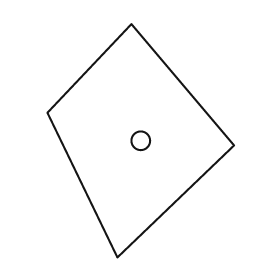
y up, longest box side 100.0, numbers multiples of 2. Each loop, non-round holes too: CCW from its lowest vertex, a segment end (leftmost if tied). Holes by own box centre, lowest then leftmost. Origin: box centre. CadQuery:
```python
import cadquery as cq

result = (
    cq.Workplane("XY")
    .moveTo(-10.0, -50.0)
    .lineTo(40.0, -2.0)
    .lineTo(-4.0, 50.0)
    .lineTo(-40.0, 12.0)
    .close()
    .moveTo(0.0, 0.0)
    .circle(4.0)
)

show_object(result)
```